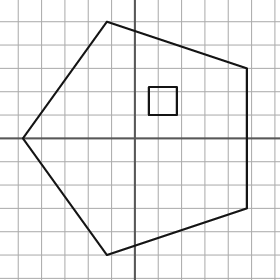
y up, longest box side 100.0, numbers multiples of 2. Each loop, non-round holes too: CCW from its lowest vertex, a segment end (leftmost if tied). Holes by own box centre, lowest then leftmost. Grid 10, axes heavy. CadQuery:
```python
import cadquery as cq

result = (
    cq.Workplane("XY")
    .moveTo(-12.0, -50.0)
    .lineTo(48.0, -30.0)
    .lineTo(48.0, 30.0)
    .lineTo(-12.0, 50.0)
    .lineTo(-48.0, 0.0)
    .close()
    .moveTo(6.0, 10.0)
    .lineTo(18.0, 10.0)
    .lineTo(18.0, 22.0)
    .lineTo(6.0, 22.0)
    .close()
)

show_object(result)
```